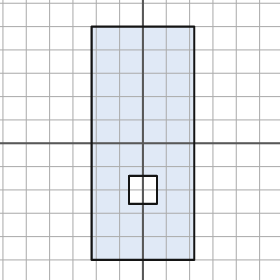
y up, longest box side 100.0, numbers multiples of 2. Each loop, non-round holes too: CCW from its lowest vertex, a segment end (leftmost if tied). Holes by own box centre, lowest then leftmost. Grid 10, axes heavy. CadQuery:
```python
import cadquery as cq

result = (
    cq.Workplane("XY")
    .moveTo(-22.0, -50.0)
    .lineTo(22.0, -50.0)
    .lineTo(22.0, 50.0)
    .lineTo(-22.0, 50.0)
    .close()
    .moveTo(-6.0, -26.0)
    .lineTo(6.0, -26.0)
    .lineTo(6.0, -14.0)
    .lineTo(-6.0, -14.0)
    .close()
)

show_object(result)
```